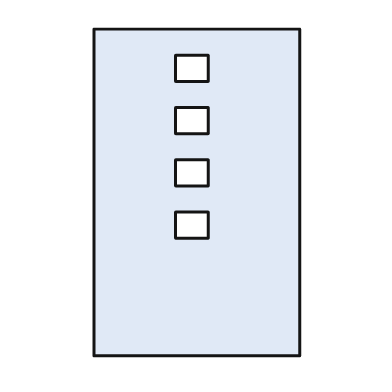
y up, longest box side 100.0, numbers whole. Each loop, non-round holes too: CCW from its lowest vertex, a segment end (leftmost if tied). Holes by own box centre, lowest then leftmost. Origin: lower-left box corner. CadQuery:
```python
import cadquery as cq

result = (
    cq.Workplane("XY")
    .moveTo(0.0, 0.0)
    .lineTo(63.0, 0.0)
    .lineTo(63.0, 100.0)
    .lineTo(0.0, 100.0)
    .close()
    .moveTo(25.0, 36.0)
    .lineTo(35.0, 36.0)
    .lineTo(35.0, 44.0)
    .lineTo(25.0, 44.0)
    .close()
    .moveTo(25.0, 52.0)
    .lineTo(35.0, 52.0)
    .lineTo(35.0, 60.0)
    .lineTo(25.0, 60.0)
    .close()
    .moveTo(25.0, 68.0)
    .lineTo(35.0, 68.0)
    .lineTo(35.0, 76.0)
    .lineTo(25.0, 76.0)
    .close()
    .moveTo(25.0, 84.0)
    .lineTo(35.0, 84.0)
    .lineTo(35.0, 92.0)
    .lineTo(25.0, 92.0)
    .close()
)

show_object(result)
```